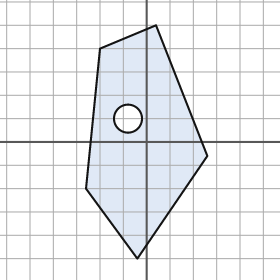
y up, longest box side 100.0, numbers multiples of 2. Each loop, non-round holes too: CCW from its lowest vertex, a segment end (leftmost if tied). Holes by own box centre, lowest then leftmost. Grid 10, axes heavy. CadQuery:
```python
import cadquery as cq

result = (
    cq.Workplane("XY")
    .moveTo(-4.0, -50.0)
    .lineTo(26.0, -6.0)
    .lineTo(4.0, 50.0)
    .lineTo(-20.0, 40.0)
    .lineTo(-26.0, -20.0)
    .close()
    .moveTo(-8.0, 10.0)
    .circle(6.0)
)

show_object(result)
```